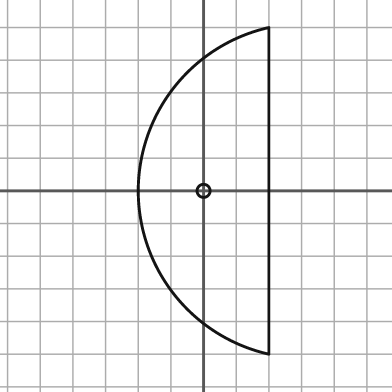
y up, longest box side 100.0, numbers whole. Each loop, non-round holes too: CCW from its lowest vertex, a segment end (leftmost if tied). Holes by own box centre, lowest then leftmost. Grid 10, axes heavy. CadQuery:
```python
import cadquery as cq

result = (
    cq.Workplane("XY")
    .moveTo(20.0, -50.0)
    .lineTo(20.0, 50.0)
    .threePointArc((-20.0, 0.0), (20.0, -50.0))
    .close()
    .moveTo(0.0, 0.0)
    .circle(2.0)
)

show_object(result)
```